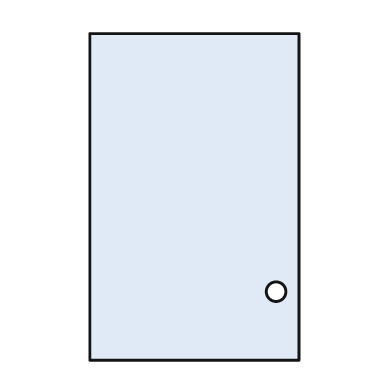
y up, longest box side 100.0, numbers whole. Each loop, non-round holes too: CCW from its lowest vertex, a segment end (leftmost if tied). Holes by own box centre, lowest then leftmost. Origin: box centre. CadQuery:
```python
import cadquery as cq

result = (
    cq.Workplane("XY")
    .moveTo(-32.0, -50.0)
    .lineTo(32.0, -50.0)
    .lineTo(32.0, 50.0)
    .lineTo(-32.0, 50.0)
    .close()
    .moveTo(25.0, -29.0)
    .circle(3.0)
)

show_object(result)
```